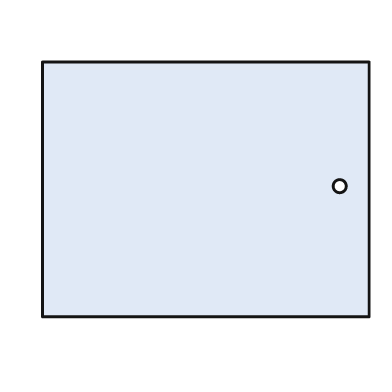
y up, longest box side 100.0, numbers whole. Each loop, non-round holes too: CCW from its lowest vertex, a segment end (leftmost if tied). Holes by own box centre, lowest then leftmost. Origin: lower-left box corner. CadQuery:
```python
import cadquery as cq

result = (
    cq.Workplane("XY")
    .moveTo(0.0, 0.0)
    .lineTo(100.0, 0.0)
    .lineTo(100.0, 78.0)
    .lineTo(0.0, 78.0)
    .close()
    .moveTo(91.0, 40.0)
    .circle(2.0)
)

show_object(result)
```